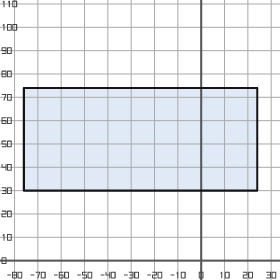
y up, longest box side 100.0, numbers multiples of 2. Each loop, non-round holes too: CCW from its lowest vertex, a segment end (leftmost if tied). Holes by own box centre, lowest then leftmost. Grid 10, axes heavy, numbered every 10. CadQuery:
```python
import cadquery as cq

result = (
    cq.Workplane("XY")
    .moveTo(-76.0, 30.0)
    .lineTo(24.0, 30.0)
    .lineTo(24.0, 74.0)
    .lineTo(-76.0, 74.0)
    .close()
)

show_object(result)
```